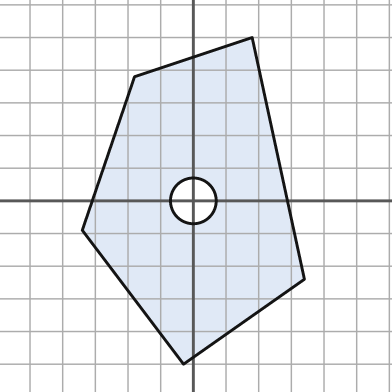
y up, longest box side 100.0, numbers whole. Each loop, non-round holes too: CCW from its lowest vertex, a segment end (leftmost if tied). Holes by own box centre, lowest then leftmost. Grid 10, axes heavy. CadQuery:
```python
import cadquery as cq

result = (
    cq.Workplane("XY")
    .moveTo(-3.0, -50.0)
    .lineTo(34.0, -24.0)
    .lineTo(18.0, 50.0)
    .lineTo(-18.0, 38.0)
    .lineTo(-34.0, -9.0)
    .close()
    .moveTo(0.0, 0.0)
    .circle(7.0)
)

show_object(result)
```